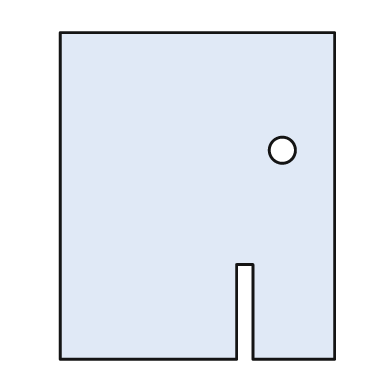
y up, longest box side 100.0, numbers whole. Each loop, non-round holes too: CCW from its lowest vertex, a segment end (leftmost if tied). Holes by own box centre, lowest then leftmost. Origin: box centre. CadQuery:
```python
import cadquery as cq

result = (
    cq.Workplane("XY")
    .moveTo(-42.0, -50.0)
    .lineTo(12.0, -50.0)
    .lineTo(12.0, -21.0)
    .lineTo(17.0, -21.0)
    .lineTo(17.0, -50.0)
    .lineTo(42.0, -50.0)
    .lineTo(42.0, 50.0)
    .lineTo(-42.0, 50.0)
    .close()
    .moveTo(26.0, 14.0)
    .circle(4.0)
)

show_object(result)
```